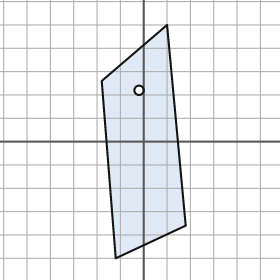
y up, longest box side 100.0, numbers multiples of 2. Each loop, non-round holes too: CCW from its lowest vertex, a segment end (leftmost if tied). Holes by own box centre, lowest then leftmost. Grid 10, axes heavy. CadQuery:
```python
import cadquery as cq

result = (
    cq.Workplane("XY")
    .moveTo(-12.0, -50.0)
    .lineTo(18.0, -36.0)
    .lineTo(10.0, 50.0)
    .lineTo(-18.0, 26.0)
    .close()
    .moveTo(-2.0, 22.0)
    .circle(2.0)
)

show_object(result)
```